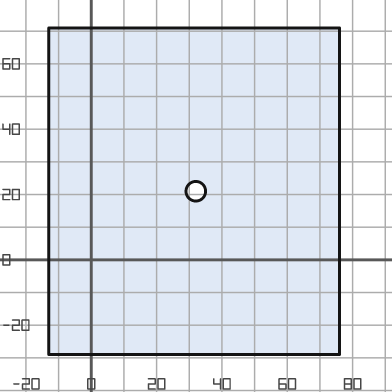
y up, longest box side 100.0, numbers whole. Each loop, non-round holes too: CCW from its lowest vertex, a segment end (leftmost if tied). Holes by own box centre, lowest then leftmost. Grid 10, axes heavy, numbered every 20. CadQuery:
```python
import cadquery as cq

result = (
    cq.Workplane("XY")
    .moveTo(-13.0, -29.0)
    .lineTo(76.0, -29.0)
    .lineTo(76.0, 71.0)
    .lineTo(-13.0, 71.0)
    .close()
    .moveTo(32.0, 21.0)
    .circle(3.0)
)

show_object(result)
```